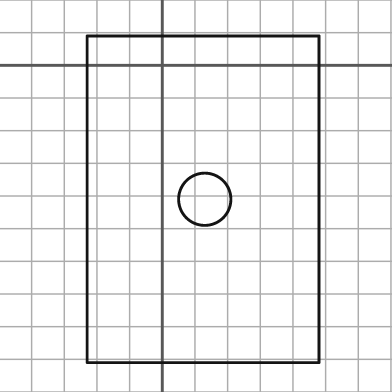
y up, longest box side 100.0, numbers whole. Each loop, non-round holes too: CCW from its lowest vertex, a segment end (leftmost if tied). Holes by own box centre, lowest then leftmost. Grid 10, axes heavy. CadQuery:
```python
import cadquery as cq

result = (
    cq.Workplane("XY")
    .moveTo(-23.0, -91.0)
    .lineTo(48.0, -91.0)
    .lineTo(48.0, 9.0)
    .lineTo(-23.0, 9.0)
    .close()
    .moveTo(13.0, -41.0)
    .circle(8.0)
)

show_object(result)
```